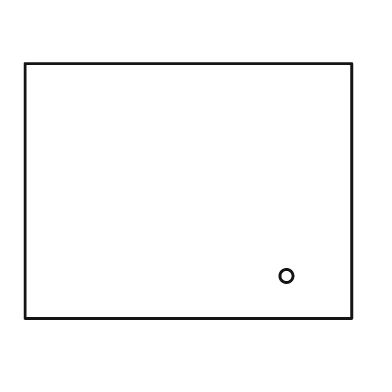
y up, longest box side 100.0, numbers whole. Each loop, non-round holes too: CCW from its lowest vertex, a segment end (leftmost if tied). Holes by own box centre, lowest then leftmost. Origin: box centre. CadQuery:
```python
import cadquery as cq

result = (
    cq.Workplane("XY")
    .moveTo(-50.0, -39.0)
    .lineTo(50.0, -39.0)
    .lineTo(50.0, 39.0)
    .lineTo(-50.0, 39.0)
    .close()
    .moveTo(30.0, -26.0)
    .circle(2.0)
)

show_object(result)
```